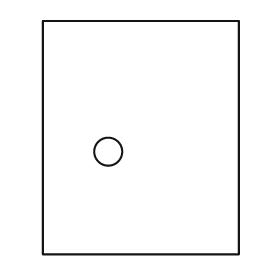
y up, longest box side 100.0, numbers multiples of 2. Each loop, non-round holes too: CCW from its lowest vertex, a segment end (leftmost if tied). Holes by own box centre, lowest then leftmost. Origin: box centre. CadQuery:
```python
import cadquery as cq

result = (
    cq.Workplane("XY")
    .moveTo(-42.0, -50.0)
    .lineTo(42.0, -50.0)
    .lineTo(42.0, 50.0)
    .lineTo(-42.0, 50.0)
    .close()
    .moveTo(-14.0, -6.0)
    .circle(6.0)
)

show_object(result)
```